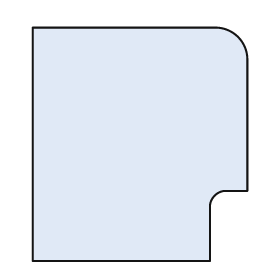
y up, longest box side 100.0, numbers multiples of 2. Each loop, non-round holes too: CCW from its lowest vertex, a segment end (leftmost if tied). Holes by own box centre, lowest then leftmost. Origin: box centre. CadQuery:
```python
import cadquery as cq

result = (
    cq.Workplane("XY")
    .moveTo(-46.0, -50.0)
    .lineTo(30.0, -50.0)
    .lineTo(30.0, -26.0)
    .threePointArc((32.0, -22.0), (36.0, -20.0))
    .lineTo(46.0, -20.0)
    .lineTo(46.0, 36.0)
    .threePointArc((42.0, 46.0), (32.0, 50.0))
    .lineTo(-46.0, 50.0)
    .close()
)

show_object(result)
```